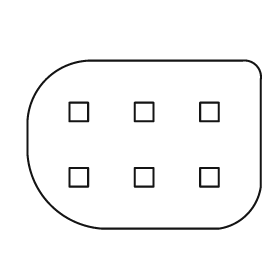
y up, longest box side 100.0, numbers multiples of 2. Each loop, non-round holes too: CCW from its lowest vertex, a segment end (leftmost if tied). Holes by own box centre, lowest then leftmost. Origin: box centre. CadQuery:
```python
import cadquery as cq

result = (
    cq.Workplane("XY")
    .moveTo(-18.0, -36.0)
    .lineTo(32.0, -36.0)
    .threePointArc((44.0, -30.0), (50.0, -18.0))
    .lineTo(50.0, 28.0)
    .threePointArc((48.0, 34.0), (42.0, 36.0))
    .lineTo(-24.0, 36.0)
    .threePointArc((-42.0, 28.0), (-50.0, 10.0))
    .lineTo(-50.0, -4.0)
    .threePointArc((-40.0, -26.0), (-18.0, -36.0))
    .close()
    .moveTo(-32.0, -18.0)
    .lineTo(-24.0, -18.0)
    .lineTo(-24.0, -10.0)
    .lineTo(-32.0, -10.0)
    .close()
    .moveTo(-4.0, -18.0)
    .lineTo(4.0, -18.0)
    .lineTo(4.0, -10.0)
    .lineTo(-4.0, -10.0)
    .close()
    .moveTo(24.0, -18.0)
    .lineTo(32.0, -18.0)
    .lineTo(32.0, -10.0)
    .lineTo(24.0, -10.0)
    .close()
    .moveTo(-32.0, 10.0)
    .lineTo(-24.0, 10.0)
    .lineTo(-24.0, 18.0)
    .lineTo(-32.0, 18.0)
    .close()
    .moveTo(-4.0, 10.0)
    .lineTo(4.0, 10.0)
    .lineTo(4.0, 18.0)
    .lineTo(-4.0, 18.0)
    .close()
    .moveTo(24.0, 10.0)
    .lineTo(32.0, 10.0)
    .lineTo(32.0, 18.0)
    .lineTo(24.0, 18.0)
    .close()
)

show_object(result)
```